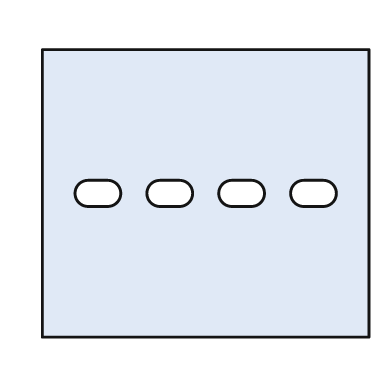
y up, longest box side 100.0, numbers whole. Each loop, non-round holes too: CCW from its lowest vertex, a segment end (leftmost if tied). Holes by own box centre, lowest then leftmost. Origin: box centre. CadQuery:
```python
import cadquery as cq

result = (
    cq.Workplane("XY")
    .moveTo(-50.0, -44.0)
    .lineTo(50.0, -44.0)
    .lineTo(50.0, 44.0)
    .lineTo(-50.0, 44.0)
    .close()
    .moveTo(-36.0, -4.0)
    .lineTo(-30.0, -4.0)
    .threePointArc((-26.0, 0.0), (-30.0, 4.0))
    .lineTo(-36.0, 4.0)
    .threePointArc((-40.0, 0.0), (-36.0, -4.0))
    .close()
    .moveTo(-14.0, -4.0)
    .lineTo(-8.0, -4.0)
    .threePointArc((-4.0, 0.0), (-8.0, 4.0))
    .lineTo(-14.0, 4.0)
    .threePointArc((-18.0, 0.0), (-14.0, -4.0))
    .close()
    .moveTo(8.0, -4.0)
    .lineTo(14.0, -4.0)
    .threePointArc((18.0, 0.0), (14.0, 4.0))
    .lineTo(8.0, 4.0)
    .threePointArc((4.0, 0.0), (8.0, -4.0))
    .close()
    .moveTo(30.0, -4.0)
    .lineTo(36.0, -4.0)
    .threePointArc((40.0, 0.0), (36.0, 4.0))
    .lineTo(30.0, 4.0)
    .threePointArc((26.0, 0.0), (30.0, -4.0))
    .close()
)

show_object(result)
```